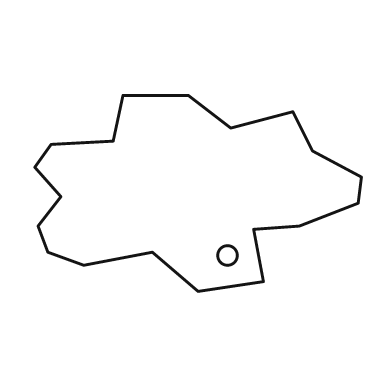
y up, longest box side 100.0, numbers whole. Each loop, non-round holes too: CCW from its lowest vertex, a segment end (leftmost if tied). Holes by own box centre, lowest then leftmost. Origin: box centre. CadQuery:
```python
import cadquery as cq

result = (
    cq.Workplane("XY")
    .moveTo(0.0, -30.0)
    .lineTo(20.0, -27.0)
    .lineTo(17.0, -11.0)
    .lineTo(31.0, -10.0)
    .lineTo(49.0, -3.0)
    .lineTo(50.0, 5.0)
    .lineTo(35.0, 13.0)
    .lineTo(29.0, 25.0)
    .lineTo(10.0, 20.0)
    .lineTo(-3.0, 30.0)
    .lineTo(-23.0, 30.0)
    .lineTo(-26.0, 16.0)
    .lineTo(-45.0, 15.0)
    .lineTo(-50.0, 8.0)
    .lineTo(-42.0, -1.0)
    .lineTo(-49.0, -10.0)
    .lineTo(-46.0, -18.0)
    .lineTo(-35.0, -22.0)
    .lineTo(-14.0, -18.0)
    .close()
    .moveTo(9.0, -19.0)
    .circle(3.0)
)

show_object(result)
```